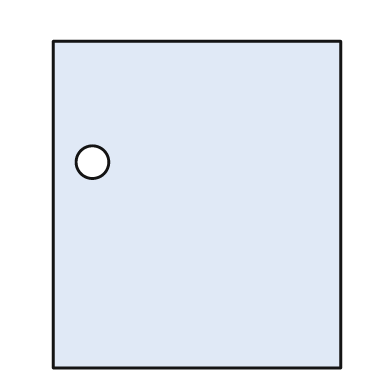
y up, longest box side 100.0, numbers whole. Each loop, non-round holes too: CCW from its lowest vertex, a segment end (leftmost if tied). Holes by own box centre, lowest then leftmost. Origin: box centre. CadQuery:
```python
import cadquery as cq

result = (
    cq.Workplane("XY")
    .moveTo(-44.0, -50.0)
    .lineTo(44.0, -50.0)
    .lineTo(44.0, 50.0)
    .lineTo(-44.0, 50.0)
    .close()
    .moveTo(-32.0, 13.0)
    .circle(5.0)
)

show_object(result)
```